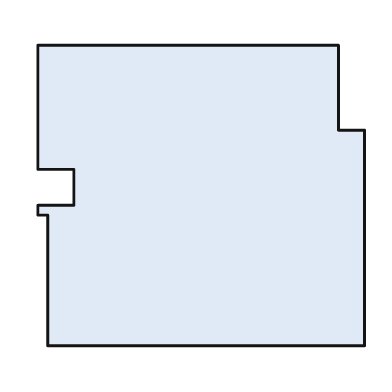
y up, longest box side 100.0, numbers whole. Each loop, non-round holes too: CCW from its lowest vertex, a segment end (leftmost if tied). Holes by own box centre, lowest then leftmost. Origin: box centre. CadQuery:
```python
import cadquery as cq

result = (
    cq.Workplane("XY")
    .moveTo(-47.0, -46.0)
    .lineTo(50.0, -46.0)
    .lineTo(50.0, 20.0)
    .lineTo(42.0, 20.0)
    .lineTo(42.0, 46.0)
    .lineTo(-50.0, 46.0)
    .lineTo(-50.0, 8.0)
    .lineTo(-39.0, 8.0)
    .lineTo(-39.0, -3.0)
    .lineTo(-50.0, -3.0)
    .lineTo(-50.0, -6.0)
    .lineTo(-47.0, -6.0)
    .close()
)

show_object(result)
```